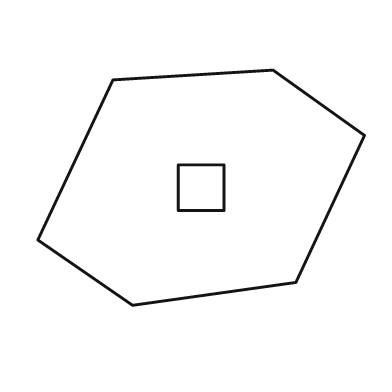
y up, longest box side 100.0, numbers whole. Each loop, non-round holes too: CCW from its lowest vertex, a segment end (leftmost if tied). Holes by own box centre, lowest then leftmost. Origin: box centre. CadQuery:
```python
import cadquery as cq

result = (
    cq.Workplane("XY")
    .moveTo(-21.0, -36.0)
    .lineTo(29.0, -29.0)
    .lineTo(50.0, 16.0)
    .lineTo(22.0, 36.0)
    .lineTo(-27.0, 33.0)
    .lineTo(-50.0, -16.0)
    .close()
    .moveTo(-7.0, -7.0)
    .lineTo(7.0, -7.0)
    .lineTo(7.0, 7.0)
    .lineTo(-7.0, 7.0)
    .close()
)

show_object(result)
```